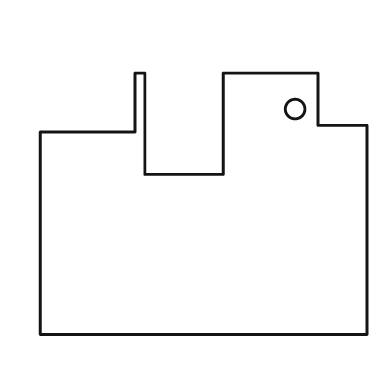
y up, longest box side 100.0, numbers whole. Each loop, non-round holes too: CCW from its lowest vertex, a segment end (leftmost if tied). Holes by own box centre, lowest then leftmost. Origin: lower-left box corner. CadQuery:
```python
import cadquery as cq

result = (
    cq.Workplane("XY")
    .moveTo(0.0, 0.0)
    .lineTo(100.0, 0.0)
    .lineTo(100.0, 64.0)
    .lineTo(85.0, 64.0)
    .lineTo(85.0, 80.0)
    .lineTo(56.0, 80.0)
    .lineTo(56.0, 49.0)
    .lineTo(32.0, 49.0)
    .lineTo(32.0, 80.0)
    .lineTo(29.0, 80.0)
    .lineTo(29.0, 62.0)
    .lineTo(0.0, 62.0)
    .close()
    .moveTo(78.0, 69.0)
    .circle(3.0)
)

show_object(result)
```